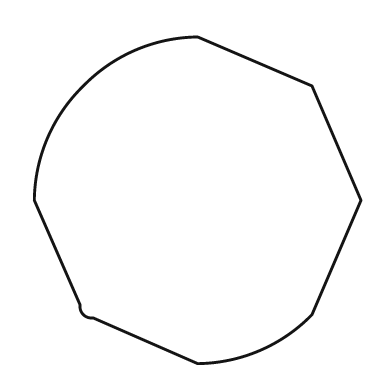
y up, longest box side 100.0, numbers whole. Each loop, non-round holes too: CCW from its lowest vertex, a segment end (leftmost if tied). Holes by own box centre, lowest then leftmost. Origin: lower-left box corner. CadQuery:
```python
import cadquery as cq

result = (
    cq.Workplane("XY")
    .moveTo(50.0, 0.0)
    .threePointArc((69.0, 4.0), (85.0, 15.0))
    .lineTo(100.0, 50.0)
    .lineTo(85.0, 85.0)
    .lineTo(50.0, 100.0)
    .threePointArc((31.0, 96.0), (15.0, 85.0))
    .threePointArc((4.0, 69.0), (0.0, 50.0))
    .lineTo(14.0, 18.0)
    .threePointArc((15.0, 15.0), (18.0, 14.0))
    .close()
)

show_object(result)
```